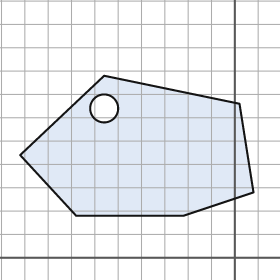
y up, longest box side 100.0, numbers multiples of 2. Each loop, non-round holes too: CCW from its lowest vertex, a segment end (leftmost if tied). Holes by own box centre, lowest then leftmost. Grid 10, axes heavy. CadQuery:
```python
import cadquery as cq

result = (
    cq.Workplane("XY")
    .moveTo(-68.0, 18.0)
    .lineTo(-22.0, 18.0)
    .lineTo(8.0, 28.0)
    .lineTo(2.0, 66.0)
    .lineTo(-56.0, 78.0)
    .lineTo(-92.0, 44.0)
    .close()
    .moveTo(-56.0, 64.0)
    .circle(6.0)
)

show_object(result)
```